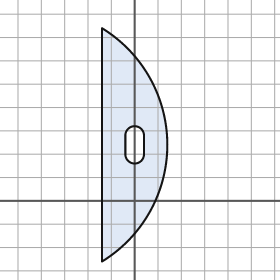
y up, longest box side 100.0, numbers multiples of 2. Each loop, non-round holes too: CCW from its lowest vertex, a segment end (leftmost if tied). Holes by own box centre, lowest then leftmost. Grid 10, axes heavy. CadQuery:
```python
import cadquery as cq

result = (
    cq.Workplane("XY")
    .moveTo(-14.0, -26.0)
    .threePointArc((14.0, 24.0), (-14.0, 74.0))
    .close()
    .moveTo(-4.0, 20.0)
    .threePointArc((0.0, 16.0), (4.0, 20.0))
    .lineTo(4.0, 28.0)
    .threePointArc((0.0, 32.0), (-4.0, 28.0))
    .close()
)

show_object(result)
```